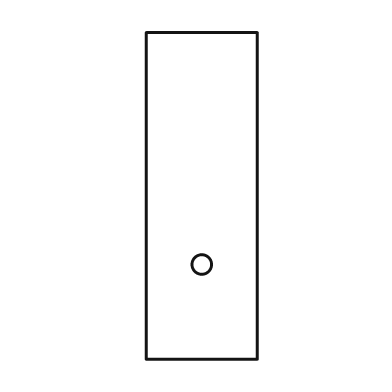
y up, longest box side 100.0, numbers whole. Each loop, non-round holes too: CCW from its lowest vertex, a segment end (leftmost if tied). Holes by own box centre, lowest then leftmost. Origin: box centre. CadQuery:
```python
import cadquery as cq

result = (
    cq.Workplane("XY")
    .moveTo(-17.0, -50.0)
    .lineTo(17.0, -50.0)
    .lineTo(17.0, 50.0)
    .lineTo(-17.0, 50.0)
    .close()
    .moveTo(0.0, -21.0)
    .circle(3.0)
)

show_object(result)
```